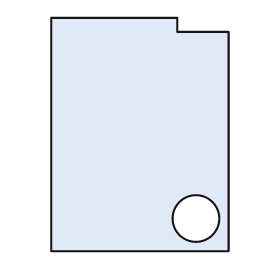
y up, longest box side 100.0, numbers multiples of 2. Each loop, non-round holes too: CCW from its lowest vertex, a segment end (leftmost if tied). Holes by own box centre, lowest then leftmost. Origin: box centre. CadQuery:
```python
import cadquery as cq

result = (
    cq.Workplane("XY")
    .moveTo(-38.0, -50.0)
    .lineTo(38.0, -50.0)
    .lineTo(38.0, 44.0)
    .lineTo(16.0, 44.0)
    .lineTo(16.0, 50.0)
    .lineTo(-38.0, 50.0)
    .close()
    .moveTo(24.0, -36.0)
    .circle(10.0)
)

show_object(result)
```